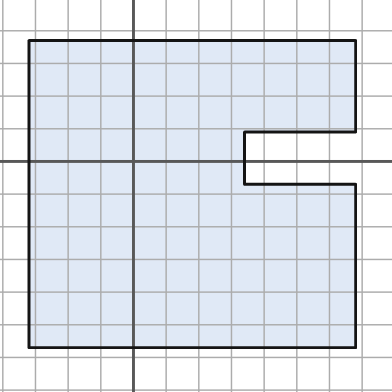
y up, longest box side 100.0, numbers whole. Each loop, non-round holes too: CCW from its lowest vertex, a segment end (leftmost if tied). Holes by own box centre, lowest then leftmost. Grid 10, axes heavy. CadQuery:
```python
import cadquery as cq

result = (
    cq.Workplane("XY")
    .moveTo(-32.0, -57.0)
    .lineTo(68.0, -57.0)
    .lineTo(68.0, -7.0)
    .lineTo(34.0, -7.0)
    .lineTo(34.0, 9.0)
    .lineTo(68.0, 9.0)
    .lineTo(68.0, 37.0)
    .lineTo(-32.0, 37.0)
    .close()
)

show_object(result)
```